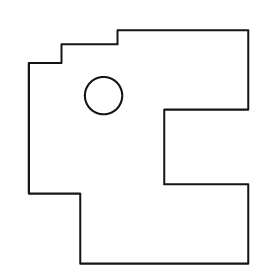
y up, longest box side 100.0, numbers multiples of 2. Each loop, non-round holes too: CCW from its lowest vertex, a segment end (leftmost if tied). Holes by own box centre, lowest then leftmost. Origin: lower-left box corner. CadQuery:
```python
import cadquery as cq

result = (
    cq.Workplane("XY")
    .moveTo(22.0, 0.0)
    .lineTo(94.0, 0.0)
    .lineTo(94.0, 34.0)
    .lineTo(58.0, 34.0)
    .lineTo(58.0, 66.0)
    .lineTo(94.0, 66.0)
    .lineTo(94.0, 100.0)
    .lineTo(38.0, 100.0)
    .lineTo(38.0, 94.0)
    .lineTo(14.0, 94.0)
    .lineTo(14.0, 86.0)
    .lineTo(0.0, 86.0)
    .lineTo(0.0, 30.0)
    .lineTo(22.0, 30.0)
    .close()
    .moveTo(32.0, 72.0)
    .circle(8.0)
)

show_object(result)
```